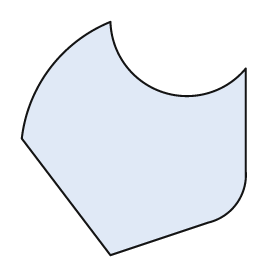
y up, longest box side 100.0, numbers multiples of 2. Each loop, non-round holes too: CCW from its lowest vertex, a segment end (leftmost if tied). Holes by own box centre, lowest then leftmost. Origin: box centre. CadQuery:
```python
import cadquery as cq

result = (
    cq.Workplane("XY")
    .moveTo(-10.0, -50.0)
    .lineTo(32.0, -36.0)
    .threePointArc((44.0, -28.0), (48.0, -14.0))
    .lineTo(48.0, 30.0)
    .threePointArc((12.0, 20.0), (-10.0, 50.0))
    .threePointArc((-36.0, 30.0), (-48.0, 0.0))
    .close()
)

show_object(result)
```